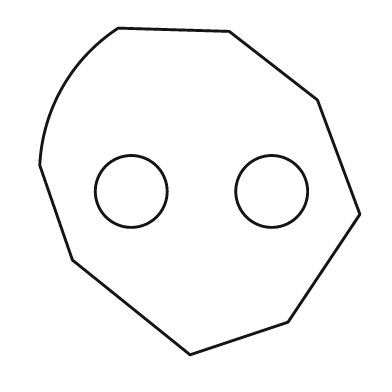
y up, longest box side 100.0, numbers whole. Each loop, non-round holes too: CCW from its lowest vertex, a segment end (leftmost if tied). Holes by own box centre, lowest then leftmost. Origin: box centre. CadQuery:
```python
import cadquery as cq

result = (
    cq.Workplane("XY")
    .moveTo(-3.0, -50.0)
    .lineTo(27.0, -40.0)
    .lineTo(49.0, -7.0)
    .lineTo(36.0, 28.0)
    .lineTo(9.0, 49.0)
    .lineTo(-25.0, 50.0)
    .threePointArc((-42.0, 32.0), (-49.0, 8.0))
    .lineTo(-39.0, -21.0)
    .close()
    .moveTo(-21.0, 0.0)
    .circle(11.0)
    .moveTo(22.0, 0.0)
    .circle(11.0)
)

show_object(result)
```